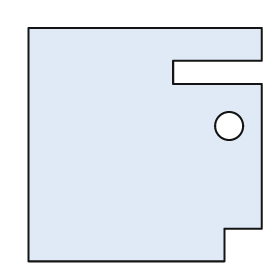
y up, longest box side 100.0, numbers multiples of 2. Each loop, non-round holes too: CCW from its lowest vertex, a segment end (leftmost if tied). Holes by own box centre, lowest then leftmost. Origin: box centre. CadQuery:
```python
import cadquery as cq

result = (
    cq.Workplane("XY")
    .moveTo(-50.0, -50.0)
    .lineTo(34.0, -50.0)
    .lineTo(34.0, -36.0)
    .lineTo(50.0, -36.0)
    .lineTo(50.0, 26.0)
    .lineTo(12.0, 26.0)
    .lineTo(12.0, 36.0)
    .lineTo(50.0, 36.0)
    .lineTo(50.0, 50.0)
    .lineTo(-50.0, 50.0)
    .close()
    .moveTo(36.0, 8.0)
    .circle(6.0)
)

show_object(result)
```